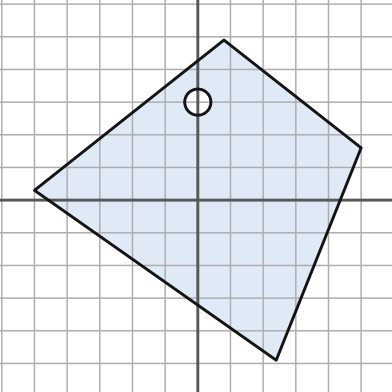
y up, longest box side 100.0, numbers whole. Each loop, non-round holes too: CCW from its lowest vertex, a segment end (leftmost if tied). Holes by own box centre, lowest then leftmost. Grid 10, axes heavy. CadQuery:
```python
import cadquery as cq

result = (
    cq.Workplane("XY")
    .moveTo(24.0, -49.0)
    .lineTo(50.0, 16.0)
    .lineTo(8.0, 49.0)
    .lineTo(-50.0, 3.0)
    .close()
    .moveTo(0.0, 30.0)
    .circle(4.0)
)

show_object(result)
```